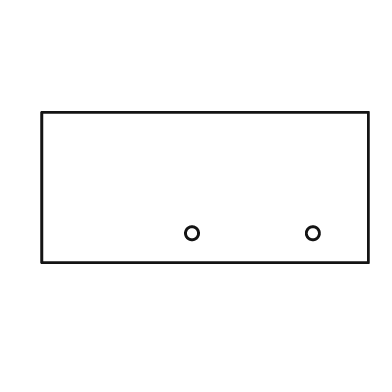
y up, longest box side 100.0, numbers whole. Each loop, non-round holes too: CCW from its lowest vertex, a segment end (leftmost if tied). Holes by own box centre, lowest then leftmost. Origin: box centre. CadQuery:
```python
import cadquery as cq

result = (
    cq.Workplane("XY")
    .moveTo(-50.0, -23.0)
    .lineTo(50.0, -23.0)
    .lineTo(50.0, 23.0)
    .lineTo(-50.0, 23.0)
    .close()
    .moveTo(-4.0, -14.0)
    .circle(2.0)
    .moveTo(33.0, -14.0)
    .circle(2.0)
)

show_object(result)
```